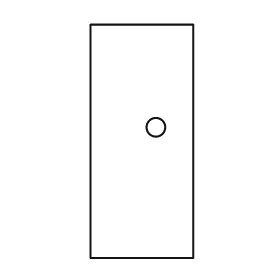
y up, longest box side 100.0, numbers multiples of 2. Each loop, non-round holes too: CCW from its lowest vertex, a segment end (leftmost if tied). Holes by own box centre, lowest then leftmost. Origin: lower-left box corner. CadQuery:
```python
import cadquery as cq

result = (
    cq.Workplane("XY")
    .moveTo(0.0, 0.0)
    .lineTo(44.0, 0.0)
    .lineTo(44.0, 100.0)
    .lineTo(0.0, 100.0)
    .close()
    .moveTo(28.0, 56.0)
    .circle(4.0)
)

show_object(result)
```